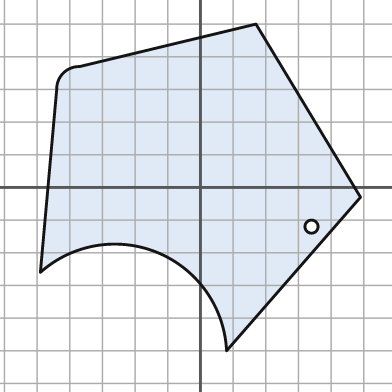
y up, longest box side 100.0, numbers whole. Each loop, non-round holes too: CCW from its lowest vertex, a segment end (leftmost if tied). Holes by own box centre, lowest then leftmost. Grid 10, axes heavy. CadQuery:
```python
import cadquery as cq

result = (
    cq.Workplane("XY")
    .moveTo(8.0, -50.0)
    .lineTo(49.0, -3.0)
    .lineTo(17.0, 50.0)
    .lineTo(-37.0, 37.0)
    .threePointArc((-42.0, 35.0), (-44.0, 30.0))
    .lineTo(-49.0, -26.0)
    .threePointArc((-13.0, -20.0), (8.0, -50.0))
    .close()
    .moveTo(34.0, -12.0)
    .circle(2.0)
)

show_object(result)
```